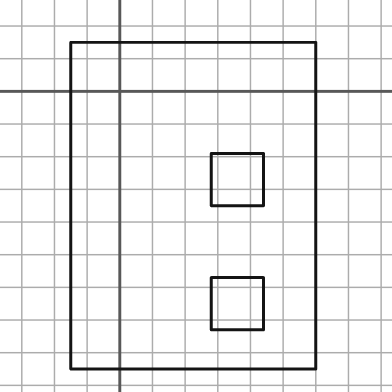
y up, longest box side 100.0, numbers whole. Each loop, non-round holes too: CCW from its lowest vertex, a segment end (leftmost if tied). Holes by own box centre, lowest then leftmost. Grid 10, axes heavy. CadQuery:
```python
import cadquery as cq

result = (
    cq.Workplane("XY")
    .moveTo(-15.0, -85.0)
    .lineTo(60.0, -85.0)
    .lineTo(60.0, 15.0)
    .lineTo(-15.0, 15.0)
    .close()
    .moveTo(28.0, -73.0)
    .lineTo(44.0, -73.0)
    .lineTo(44.0, -57.0)
    .lineTo(28.0, -57.0)
    .close()
    .moveTo(28.0, -35.0)
    .lineTo(44.0, -35.0)
    .lineTo(44.0, -19.0)
    .lineTo(28.0, -19.0)
    .close()
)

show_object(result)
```